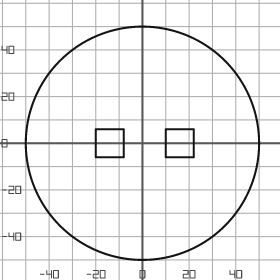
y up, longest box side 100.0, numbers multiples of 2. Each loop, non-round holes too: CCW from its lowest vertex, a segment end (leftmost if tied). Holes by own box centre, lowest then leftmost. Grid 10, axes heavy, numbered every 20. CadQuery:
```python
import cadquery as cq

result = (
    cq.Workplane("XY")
    .moveTo(0.0, 0.0)
    .circle(50.0)
    .moveTo(-20.0, -6.0)
    .lineTo(-8.0, -6.0)
    .lineTo(-8.0, 6.0)
    .lineTo(-20.0, 6.0)
    .close()
    .moveTo(10.0, -6.0)
    .lineTo(22.0, -6.0)
    .lineTo(22.0, 6.0)
    .lineTo(10.0, 6.0)
    .close()
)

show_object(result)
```